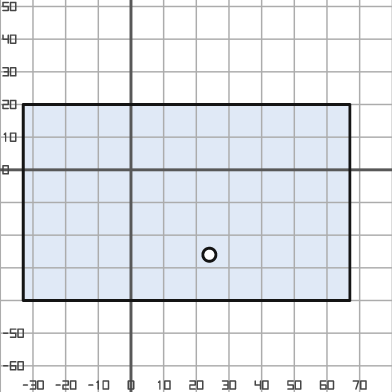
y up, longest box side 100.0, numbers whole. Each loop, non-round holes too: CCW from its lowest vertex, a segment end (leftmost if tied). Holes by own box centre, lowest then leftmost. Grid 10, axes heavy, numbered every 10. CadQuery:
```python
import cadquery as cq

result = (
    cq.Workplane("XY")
    .moveTo(-33.0, -40.0)
    .lineTo(67.0, -40.0)
    .lineTo(67.0, 20.0)
    .lineTo(-33.0, 20.0)
    .close()
    .moveTo(24.0, -26.0)
    .circle(2.0)
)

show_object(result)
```